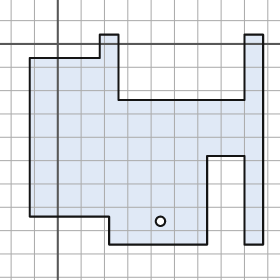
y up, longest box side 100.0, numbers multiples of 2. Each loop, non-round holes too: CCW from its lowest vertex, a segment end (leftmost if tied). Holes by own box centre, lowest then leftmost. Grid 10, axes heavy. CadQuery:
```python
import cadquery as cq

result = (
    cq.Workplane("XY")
    .moveTo(22.0, -86.0)
    .lineTo(64.0, -86.0)
    .lineTo(64.0, -48.0)
    .lineTo(80.0, -48.0)
    .lineTo(80.0, -86.0)
    .lineTo(88.0, -86.0)
    .lineTo(88.0, 4.0)
    .lineTo(80.0, 4.0)
    .lineTo(80.0, -24.0)
    .lineTo(26.0, -24.0)
    .lineTo(26.0, 4.0)
    .lineTo(18.0, 4.0)
    .lineTo(18.0, -6.0)
    .lineTo(-12.0, -6.0)
    .lineTo(-12.0, -74.0)
    .lineTo(22.0, -74.0)
    .close()
    .moveTo(44.0, -76.0)
    .circle(2.0)
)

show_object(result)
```